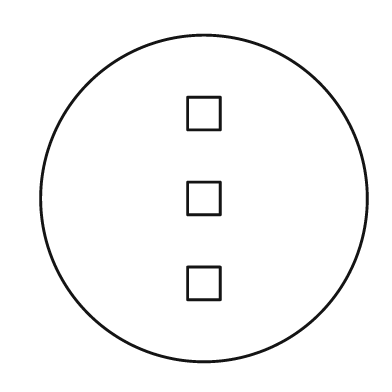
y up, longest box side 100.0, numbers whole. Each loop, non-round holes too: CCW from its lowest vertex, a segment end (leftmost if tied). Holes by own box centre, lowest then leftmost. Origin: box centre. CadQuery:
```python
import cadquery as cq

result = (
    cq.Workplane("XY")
    .moveTo(0.0, 0.0)
    .circle(50.0)
    .moveTo(-5.0, -31.0)
    .lineTo(5.0, -31.0)
    .lineTo(5.0, -21.0)
    .lineTo(-5.0, -21.0)
    .close()
    .moveTo(-5.0, -5.0)
    .lineTo(5.0, -5.0)
    .lineTo(5.0, 5.0)
    .lineTo(-5.0, 5.0)
    .close()
    .moveTo(-5.0, 21.0)
    .lineTo(5.0, 21.0)
    .lineTo(5.0, 31.0)
    .lineTo(-5.0, 31.0)
    .close()
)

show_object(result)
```